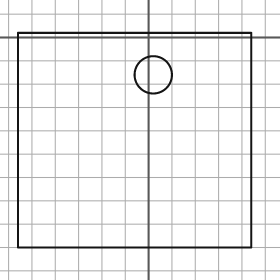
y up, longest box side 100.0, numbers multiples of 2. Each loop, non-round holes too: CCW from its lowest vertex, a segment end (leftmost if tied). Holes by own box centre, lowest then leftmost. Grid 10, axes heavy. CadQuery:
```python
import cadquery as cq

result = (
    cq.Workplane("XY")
    .moveTo(-56.0, -90.0)
    .lineTo(44.0, -90.0)
    .lineTo(44.0, 2.0)
    .lineTo(-56.0, 2.0)
    .close()
    .moveTo(2.0, -16.0)
    .circle(8.0)
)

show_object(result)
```